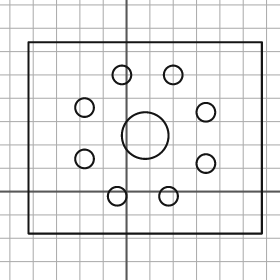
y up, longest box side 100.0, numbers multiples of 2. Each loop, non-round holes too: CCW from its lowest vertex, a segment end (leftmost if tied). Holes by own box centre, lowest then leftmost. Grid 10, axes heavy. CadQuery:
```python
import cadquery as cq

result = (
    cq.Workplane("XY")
    .moveTo(-42.0, -18.0)
    .lineTo(58.0, -18.0)
    .lineTo(58.0, 64.0)
    .lineTo(-42.0, 64.0)
    .close()
    .moveTo(-4.0, -2.0)
    .circle(4.0)
    .moveTo(18.0, -2.0)
    .circle(4.0)
    .moveTo(34.0, 12.0)
    .circle(4.0)
    .moveTo(-18.0, 14.0)
    .circle(4.0)
    .moveTo(8.0, 24.0)
    .circle(10.0)
    .moveTo(34.0, 34.0)
    .circle(4.0)
    .moveTo(-18.0, 36.0)
    .circle(4.0)
    .moveTo(-2.0, 50.0)
    .circle(4.0)
    .moveTo(20.0, 50.0)
    .circle(4.0)
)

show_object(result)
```